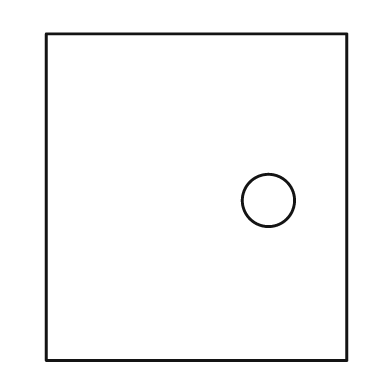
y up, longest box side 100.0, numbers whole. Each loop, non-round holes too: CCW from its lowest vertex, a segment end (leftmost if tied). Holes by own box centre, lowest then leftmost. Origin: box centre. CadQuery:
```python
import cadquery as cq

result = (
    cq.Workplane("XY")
    .moveTo(-46.0, -50.0)
    .lineTo(46.0, -50.0)
    .lineTo(46.0, 50.0)
    .lineTo(-46.0, 50.0)
    .close()
    .moveTo(22.0, -1.0)
    .circle(8.0)
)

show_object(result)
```